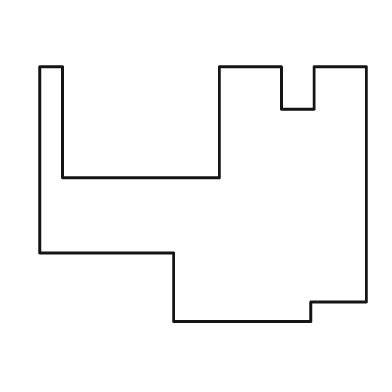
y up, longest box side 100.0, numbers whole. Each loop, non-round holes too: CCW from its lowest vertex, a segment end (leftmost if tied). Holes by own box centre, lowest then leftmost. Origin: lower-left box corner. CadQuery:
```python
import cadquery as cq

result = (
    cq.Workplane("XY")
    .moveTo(41.0, 0.0)
    .lineTo(83.0, 0.0)
    .lineTo(83.0, 6.0)
    .lineTo(100.0, 6.0)
    .lineTo(100.0, 78.0)
    .lineTo(84.0, 78.0)
    .lineTo(84.0, 65.0)
    .lineTo(74.0, 65.0)
    .lineTo(74.0, 78.0)
    .lineTo(55.0, 78.0)
    .lineTo(55.0, 44.0)
    .lineTo(7.0, 44.0)
    .lineTo(7.0, 78.0)
    .lineTo(0.0, 78.0)
    .lineTo(0.0, 21.0)
    .lineTo(41.0, 21.0)
    .close()
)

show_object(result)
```